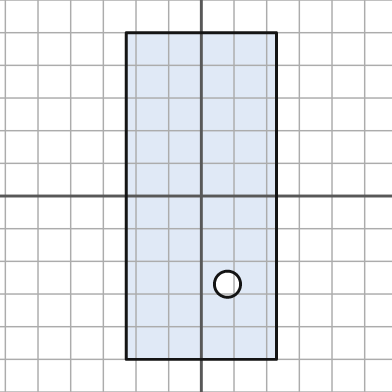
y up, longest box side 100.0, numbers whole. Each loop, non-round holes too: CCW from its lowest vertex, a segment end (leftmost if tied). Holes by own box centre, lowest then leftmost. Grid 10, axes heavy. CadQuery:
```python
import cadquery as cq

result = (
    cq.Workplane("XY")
    .moveTo(-23.0, -50.0)
    .lineTo(23.0, -50.0)
    .lineTo(23.0, 50.0)
    .lineTo(-23.0, 50.0)
    .close()
    .moveTo(8.0, -27.0)
    .circle(4.0)
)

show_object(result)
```